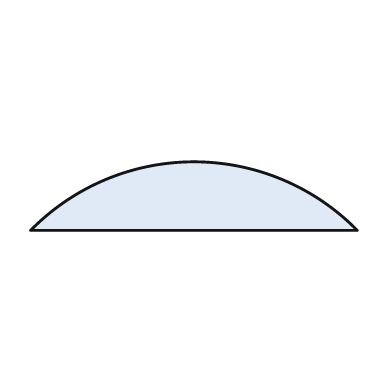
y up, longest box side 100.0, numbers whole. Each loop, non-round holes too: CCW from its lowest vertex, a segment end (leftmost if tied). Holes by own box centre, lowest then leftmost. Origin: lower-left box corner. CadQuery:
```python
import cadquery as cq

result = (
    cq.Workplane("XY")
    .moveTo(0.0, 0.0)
    .lineTo(100.0, 0.0)
    .threePointArc((50.0, 21.0), (0.0, 0.0))
    .close()
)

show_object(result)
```